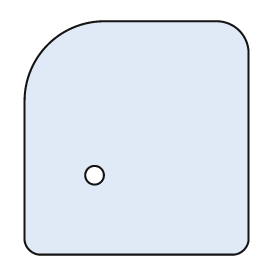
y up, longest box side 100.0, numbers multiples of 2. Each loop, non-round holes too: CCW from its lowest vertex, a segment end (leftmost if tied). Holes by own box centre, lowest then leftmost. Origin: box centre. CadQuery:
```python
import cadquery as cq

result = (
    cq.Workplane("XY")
    .moveTo(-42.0, -50.0)
    .lineTo(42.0, -50.0)
    .threePointArc((46.0, -48.0), (48.0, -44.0))
    .lineTo(48.0, 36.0)
    .threePointArc((44.0, 46.0), (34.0, 50.0))
    .lineTo(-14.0, 50.0)
    .threePointArc((-38.0, 40.0), (-48.0, 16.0))
    .lineTo(-48.0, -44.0)
    .threePointArc((-46.0, -48.0), (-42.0, -50.0))
    .close()
    .moveTo(-18.0, -16.0)
    .circle(4.0)
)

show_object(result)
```